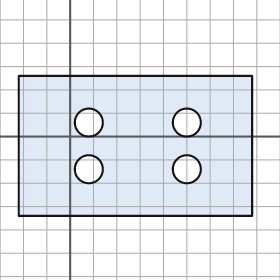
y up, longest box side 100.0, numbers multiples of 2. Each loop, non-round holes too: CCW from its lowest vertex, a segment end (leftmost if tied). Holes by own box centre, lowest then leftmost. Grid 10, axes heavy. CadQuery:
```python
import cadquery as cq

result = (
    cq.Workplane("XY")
    .moveTo(-22.0, -34.0)
    .lineTo(78.0, -34.0)
    .lineTo(78.0, 26.0)
    .lineTo(-22.0, 26.0)
    .close()
    .moveTo(8.0, -14.0)
    .circle(6.0)
    .moveTo(50.0, -14.0)
    .circle(6.0)
    .moveTo(8.0, 6.0)
    .circle(6.0)
    .moveTo(50.0, 6.0)
    .circle(6.0)
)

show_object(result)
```